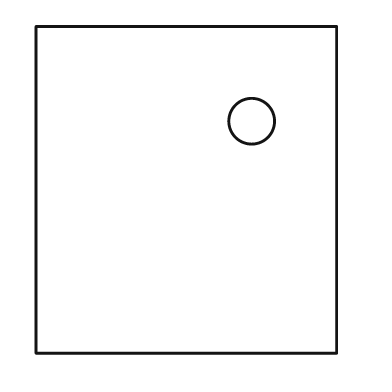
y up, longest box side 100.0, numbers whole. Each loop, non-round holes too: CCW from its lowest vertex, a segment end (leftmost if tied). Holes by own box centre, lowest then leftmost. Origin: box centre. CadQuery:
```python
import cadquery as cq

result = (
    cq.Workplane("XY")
    .moveTo(-46.0, -50.0)
    .lineTo(46.0, -50.0)
    .lineTo(46.0, 50.0)
    .lineTo(-46.0, 50.0)
    .close()
    .moveTo(20.0, 21.0)
    .circle(7.0)
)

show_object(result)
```